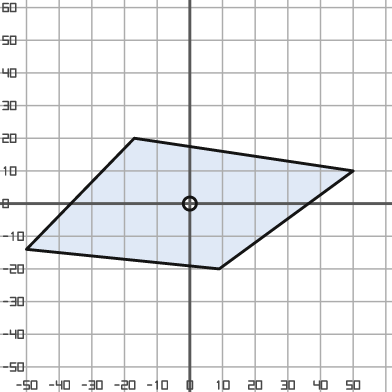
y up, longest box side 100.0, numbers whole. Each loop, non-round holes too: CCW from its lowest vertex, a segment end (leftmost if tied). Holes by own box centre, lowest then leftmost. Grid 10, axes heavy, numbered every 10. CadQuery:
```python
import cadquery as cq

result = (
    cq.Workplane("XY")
    .moveTo(9.0, -20.0)
    .lineTo(50.0, 10.0)
    .lineTo(-17.0, 20.0)
    .lineTo(-50.0, -14.0)
    .close()
    .moveTo(0.0, 0.0)
    .circle(2.0)
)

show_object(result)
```